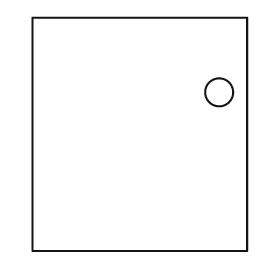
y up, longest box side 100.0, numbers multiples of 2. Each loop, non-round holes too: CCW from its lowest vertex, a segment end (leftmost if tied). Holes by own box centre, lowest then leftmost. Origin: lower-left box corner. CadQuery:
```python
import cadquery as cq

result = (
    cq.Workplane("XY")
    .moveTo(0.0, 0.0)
    .lineTo(92.0, 0.0)
    .lineTo(92.0, 100.0)
    .lineTo(0.0, 100.0)
    .close()
    .moveTo(80.0, 68.0)
    .circle(6.0)
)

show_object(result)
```